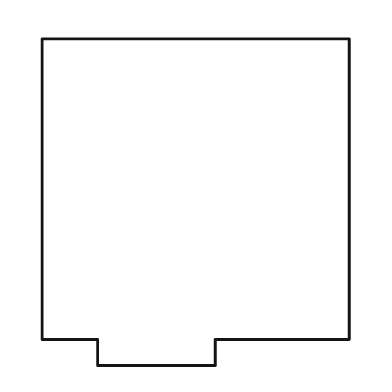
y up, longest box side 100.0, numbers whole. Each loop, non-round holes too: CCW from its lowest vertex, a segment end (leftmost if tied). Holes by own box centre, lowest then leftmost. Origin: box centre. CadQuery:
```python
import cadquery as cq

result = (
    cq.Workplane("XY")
    .moveTo(-30.0, -50.0)
    .lineTo(6.0, -50.0)
    .lineTo(6.0, -42.0)
    .lineTo(47.0, -42.0)
    .lineTo(47.0, 50.0)
    .lineTo(-47.0, 50.0)
    .lineTo(-47.0, -42.0)
    .lineTo(-30.0, -42.0)
    .close()
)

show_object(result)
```